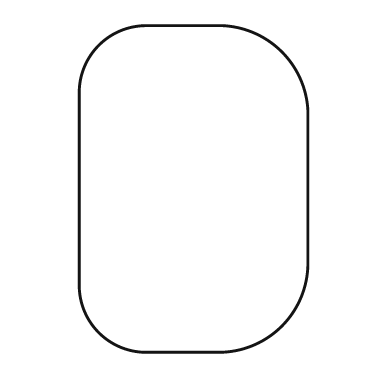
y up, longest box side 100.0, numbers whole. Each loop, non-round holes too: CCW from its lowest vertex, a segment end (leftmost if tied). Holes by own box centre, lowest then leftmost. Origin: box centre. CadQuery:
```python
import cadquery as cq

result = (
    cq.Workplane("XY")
    .moveTo(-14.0, -50.0)
    .lineTo(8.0, -50.0)
    .threePointArc((27.0, -42.0), (35.0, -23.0))
    .lineTo(35.0, 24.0)
    .threePointArc((27.0, 42.0), (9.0, 50.0))
    .lineTo(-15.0, 50.0)
    .threePointArc((-29.0, 44.0), (-35.0, 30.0))
    .lineTo(-35.0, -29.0)
    .threePointArc((-29.0, -44.0), (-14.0, -50.0))
    .close()
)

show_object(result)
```